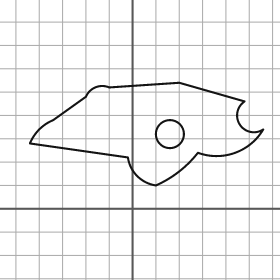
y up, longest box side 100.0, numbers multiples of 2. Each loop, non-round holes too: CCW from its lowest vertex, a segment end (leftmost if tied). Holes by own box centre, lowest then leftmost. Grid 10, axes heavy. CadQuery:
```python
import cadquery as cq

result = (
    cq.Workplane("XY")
    .moveTo(10.0, 10.0)
    .threePointArc((20.0, 16.0), (28.0, 24.0))
    .threePointArc((44.0, 24.0), (56.0, 34.0))
    .threePointArc((46.0, 36.0), (48.0, 46.0))
    .lineTo(20.0, 54.0)
    .lineTo(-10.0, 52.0)
    .threePointArc((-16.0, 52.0), (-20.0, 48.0))
    .lineTo(-34.0, 38.0)
    .threePointArc((-40.0, 34.0), (-44.0, 28.0))
    .lineTo(-2.0, 22.0)
    .threePointArc((2.0, 14.0), (10.0, 10.0))
    .close()
    .moveTo(16.0, 32.0)
    .circle(6.0)
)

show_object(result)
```